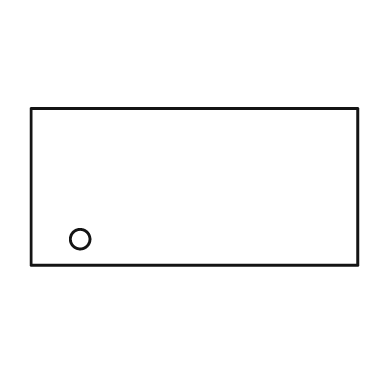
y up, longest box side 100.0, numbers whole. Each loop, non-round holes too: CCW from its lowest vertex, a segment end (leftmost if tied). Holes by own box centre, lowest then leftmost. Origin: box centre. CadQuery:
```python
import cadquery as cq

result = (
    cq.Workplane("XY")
    .moveTo(-50.0, -24.0)
    .lineTo(50.0, -24.0)
    .lineTo(50.0, 24.0)
    .lineTo(-50.0, 24.0)
    .close()
    .moveTo(-35.0, -16.0)
    .circle(3.0)
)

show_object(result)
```